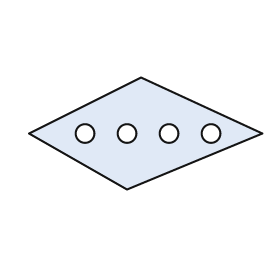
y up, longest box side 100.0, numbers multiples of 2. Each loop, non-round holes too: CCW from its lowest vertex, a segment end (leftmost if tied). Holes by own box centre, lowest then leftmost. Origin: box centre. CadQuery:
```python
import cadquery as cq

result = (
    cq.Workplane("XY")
    .moveTo(-8.0, -24.0)
    .lineTo(50.0, 0.0)
    .lineTo(-2.0, 24.0)
    .lineTo(-50.0, 0.0)
    .close()
    .moveTo(-26.0, 0.0)
    .circle(4.0)
    .moveTo(-8.0, 0.0)
    .circle(4.0)
    .moveTo(10.0, 0.0)
    .circle(4.0)
    .moveTo(28.0, 0.0)
    .circle(4.0)
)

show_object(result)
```